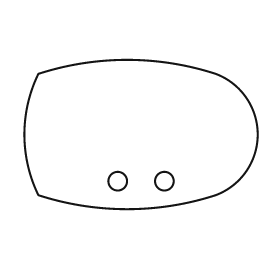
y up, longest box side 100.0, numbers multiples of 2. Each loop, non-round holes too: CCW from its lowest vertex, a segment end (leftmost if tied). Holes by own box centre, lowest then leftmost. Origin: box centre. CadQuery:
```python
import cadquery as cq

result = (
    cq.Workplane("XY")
    .moveTo(-44.0, -26.0)
    .threePointArc((-6.0, -32.0), (32.0, -26.0))
    .threePointArc((50.0, 0.0), (32.0, 26.0))
    .threePointArc((-6.0, 32.0), (-44.0, 26.0))
    .threePointArc((-50.0, 0.0), (-44.0, -26.0))
    .close()
    .moveTo(-10.0, -20.0)
    .circle(4.0)
    .moveTo(10.0, -20.0)
    .circle(4.0)
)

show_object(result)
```